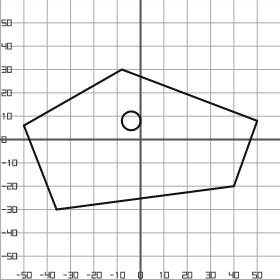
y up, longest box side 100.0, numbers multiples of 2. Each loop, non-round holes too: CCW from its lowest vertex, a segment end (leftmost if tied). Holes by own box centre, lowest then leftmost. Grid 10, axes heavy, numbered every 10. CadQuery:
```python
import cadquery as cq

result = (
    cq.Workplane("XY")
    .moveTo(-36.0, -30.0)
    .lineTo(40.0, -20.0)
    .lineTo(50.0, 8.0)
    .lineTo(-8.0, 30.0)
    .lineTo(-50.0, 6.0)
    .close()
    .moveTo(-4.0, 8.0)
    .circle(4.0)
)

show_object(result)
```